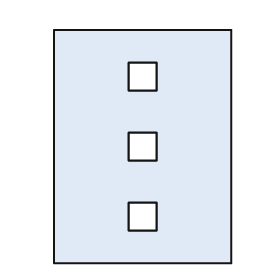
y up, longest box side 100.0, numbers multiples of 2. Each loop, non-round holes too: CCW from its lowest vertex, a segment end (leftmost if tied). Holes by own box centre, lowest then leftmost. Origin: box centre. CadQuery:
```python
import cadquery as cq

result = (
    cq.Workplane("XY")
    .moveTo(-38.0, -50.0)
    .lineTo(38.0, -50.0)
    .lineTo(38.0, 50.0)
    .lineTo(-38.0, 50.0)
    .close()
    .moveTo(-6.0, -36.0)
    .lineTo(6.0, -36.0)
    .lineTo(6.0, -24.0)
    .lineTo(-6.0, -24.0)
    .close()
    .moveTo(-6.0, -6.0)
    .lineTo(6.0, -6.0)
    .lineTo(6.0, 6.0)
    .lineTo(-6.0, 6.0)
    .close()
    .moveTo(-6.0, 24.0)
    .lineTo(6.0, 24.0)
    .lineTo(6.0, 36.0)
    .lineTo(-6.0, 36.0)
    .close()
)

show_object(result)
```